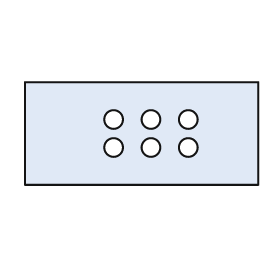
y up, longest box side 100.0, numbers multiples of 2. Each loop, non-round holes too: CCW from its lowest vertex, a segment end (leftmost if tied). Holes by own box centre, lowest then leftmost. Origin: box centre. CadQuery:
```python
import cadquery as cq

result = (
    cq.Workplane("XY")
    .moveTo(-50.0, -22.0)
    .lineTo(50.0, -22.0)
    .lineTo(50.0, 22.0)
    .lineTo(-50.0, 22.0)
    .close()
    .moveTo(-12.0, -6.0)
    .circle(4.0)
    .moveTo(4.0, -6.0)
    .circle(4.0)
    .moveTo(20.0, -6.0)
    .circle(4.0)
    .moveTo(-12.0, 6.0)
    .circle(4.0)
    .moveTo(4.0, 6.0)
    .circle(4.0)
    .moveTo(20.0, 6.0)
    .circle(4.0)
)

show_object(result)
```